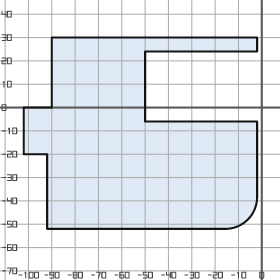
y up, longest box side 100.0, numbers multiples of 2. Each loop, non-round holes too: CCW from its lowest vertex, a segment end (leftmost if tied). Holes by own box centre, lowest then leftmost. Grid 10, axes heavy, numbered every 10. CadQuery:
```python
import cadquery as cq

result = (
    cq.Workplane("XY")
    .moveTo(-92.0, -52.0)
    .lineTo(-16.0, -52.0)
    .threePointArc((-6.0, -48.0), (-2.0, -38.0))
    .lineTo(-2.0, -6.0)
    .lineTo(-50.0, -6.0)
    .lineTo(-50.0, 24.0)
    .lineTo(-2.0, 24.0)
    .lineTo(-2.0, 30.0)
    .lineTo(-90.0, 30.0)
    .lineTo(-90.0, 0.0)
    .lineTo(-102.0, 0.0)
    .lineTo(-102.0, -20.0)
    .lineTo(-92.0, -20.0)
    .close()
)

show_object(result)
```